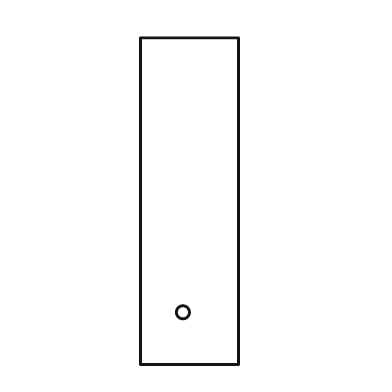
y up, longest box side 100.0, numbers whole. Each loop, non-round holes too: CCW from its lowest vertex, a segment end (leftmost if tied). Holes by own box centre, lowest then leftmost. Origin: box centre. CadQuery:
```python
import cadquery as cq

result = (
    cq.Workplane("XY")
    .moveTo(-15.0, -50.0)
    .lineTo(15.0, -50.0)
    .lineTo(15.0, 50.0)
    .lineTo(-15.0, 50.0)
    .close()
    .moveTo(-2.0, -34.0)
    .circle(2.0)
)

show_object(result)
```